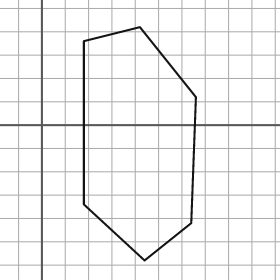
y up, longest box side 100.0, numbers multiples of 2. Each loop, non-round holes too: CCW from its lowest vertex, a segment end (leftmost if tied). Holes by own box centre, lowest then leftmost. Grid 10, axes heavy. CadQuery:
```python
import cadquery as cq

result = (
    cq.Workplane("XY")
    .moveTo(44.0, -58.0)
    .lineTo(64.0, -42.0)
    .lineTo(66.0, 12.0)
    .lineTo(42.0, 42.0)
    .lineTo(18.0, 36.0)
    .lineTo(18.0, -34.0)
    .close()
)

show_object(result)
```